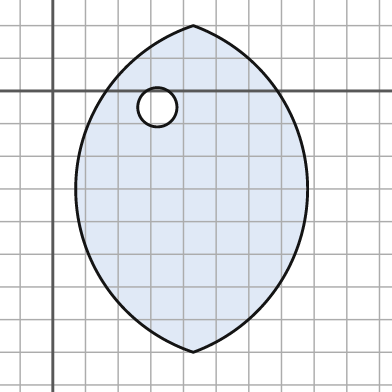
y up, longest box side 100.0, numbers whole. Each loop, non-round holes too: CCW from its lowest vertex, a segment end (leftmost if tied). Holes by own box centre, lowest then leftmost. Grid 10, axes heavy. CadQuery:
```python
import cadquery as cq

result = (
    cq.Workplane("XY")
    .moveTo(43.0, -80.0)
    .threePointArc((78.0, -30.0), (43.0, 20.0))
    .threePointArc((7.0, -30.0), (43.0, -80.0))
    .close()
    .moveTo(32.0, -5.0)
    .circle(6.0)
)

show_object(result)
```